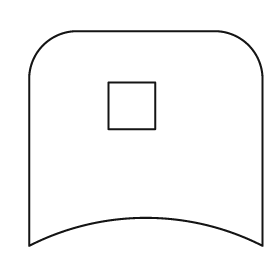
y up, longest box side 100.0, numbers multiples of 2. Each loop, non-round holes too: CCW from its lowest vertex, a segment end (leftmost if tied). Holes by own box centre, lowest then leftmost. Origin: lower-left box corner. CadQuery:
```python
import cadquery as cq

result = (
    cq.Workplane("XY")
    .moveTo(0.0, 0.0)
    .threePointArc((50.0, 12.0), (100.0, 0.0))
    .lineTo(100.0, 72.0)
    .threePointArc((94.0, 86.0), (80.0, 92.0))
    .lineTo(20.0, 92.0)
    .threePointArc((6.0, 86.0), (0.0, 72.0))
    .close()
    .moveTo(34.0, 50.0)
    .lineTo(54.0, 50.0)
    .lineTo(54.0, 70.0)
    .lineTo(34.0, 70.0)
    .close()
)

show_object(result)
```